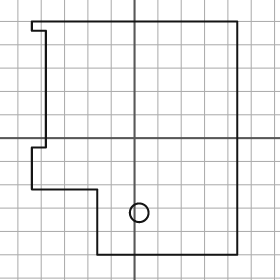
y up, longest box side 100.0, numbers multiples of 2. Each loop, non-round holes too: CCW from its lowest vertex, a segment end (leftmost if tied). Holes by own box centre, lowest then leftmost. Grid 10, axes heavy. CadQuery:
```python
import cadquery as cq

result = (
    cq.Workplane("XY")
    .moveTo(-16.0, -50.0)
    .lineTo(44.0, -50.0)
    .lineTo(44.0, 50.0)
    .lineTo(-44.0, 50.0)
    .lineTo(-44.0, 46.0)
    .lineTo(-38.0, 46.0)
    .lineTo(-38.0, -4.0)
    .lineTo(-44.0, -4.0)
    .lineTo(-44.0, -22.0)
    .lineTo(-16.0, -22.0)
    .close()
    .moveTo(2.0, -32.0)
    .circle(4.0)
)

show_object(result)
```